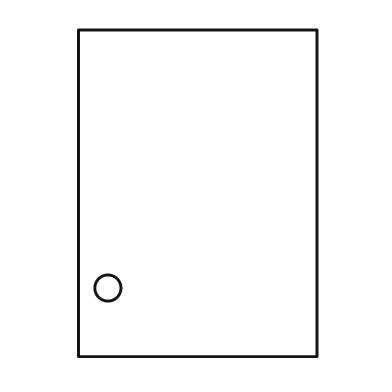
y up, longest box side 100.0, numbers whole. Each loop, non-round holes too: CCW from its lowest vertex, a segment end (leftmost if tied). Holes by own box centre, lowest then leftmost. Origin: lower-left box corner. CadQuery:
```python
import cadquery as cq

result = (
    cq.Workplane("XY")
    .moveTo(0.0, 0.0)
    .lineTo(73.0, 0.0)
    .lineTo(73.0, 100.0)
    .lineTo(0.0, 100.0)
    .close()
    .moveTo(9.0, 21.0)
    .circle(4.0)
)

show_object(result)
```